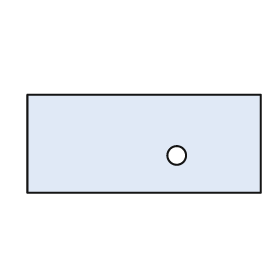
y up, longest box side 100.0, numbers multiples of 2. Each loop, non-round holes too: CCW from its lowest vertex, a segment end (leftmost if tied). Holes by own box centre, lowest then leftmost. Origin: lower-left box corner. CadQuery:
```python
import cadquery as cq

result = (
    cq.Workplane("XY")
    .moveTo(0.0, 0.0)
    .lineTo(100.0, 0.0)
    .lineTo(100.0, 42.0)
    .lineTo(0.0, 42.0)
    .close()
    .moveTo(64.0, 16.0)
    .circle(4.0)
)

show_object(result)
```